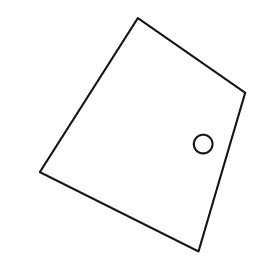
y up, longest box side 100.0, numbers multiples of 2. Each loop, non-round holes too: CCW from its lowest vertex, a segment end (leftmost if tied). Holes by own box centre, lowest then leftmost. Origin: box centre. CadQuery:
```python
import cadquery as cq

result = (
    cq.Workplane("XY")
    .moveTo(24.0, -50.0)
    .lineTo(44.0, 18.0)
    .lineTo(-2.0, 50.0)
    .lineTo(-44.0, -16.0)
    .close()
    .moveTo(26.0, -4.0)
    .circle(4.0)
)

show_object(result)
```